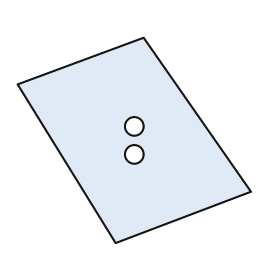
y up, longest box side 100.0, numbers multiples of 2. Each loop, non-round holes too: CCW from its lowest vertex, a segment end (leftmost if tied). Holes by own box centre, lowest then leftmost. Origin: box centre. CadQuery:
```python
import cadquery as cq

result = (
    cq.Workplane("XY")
    .moveTo(-8.0, -44.0)
    .lineTo(50.0, -22.0)
    .lineTo(4.0, 44.0)
    .lineTo(-50.0, 24.0)
    .close()
    .moveTo(0.0, -6.0)
    .circle(4.0)
    .moveTo(0.0, 6.0)
    .circle(4.0)
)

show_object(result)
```